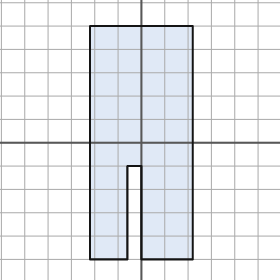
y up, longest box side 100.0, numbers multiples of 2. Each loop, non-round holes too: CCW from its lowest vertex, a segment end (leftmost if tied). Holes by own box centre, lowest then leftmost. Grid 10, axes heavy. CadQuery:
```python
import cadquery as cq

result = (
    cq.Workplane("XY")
    .moveTo(-22.0, -50.0)
    .lineTo(-6.0, -50.0)
    .lineTo(-6.0, -10.0)
    .lineTo(0.0, -10.0)
    .lineTo(0.0, -50.0)
    .lineTo(22.0, -50.0)
    .lineTo(22.0, 50.0)
    .lineTo(-22.0, 50.0)
    .close()
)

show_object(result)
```